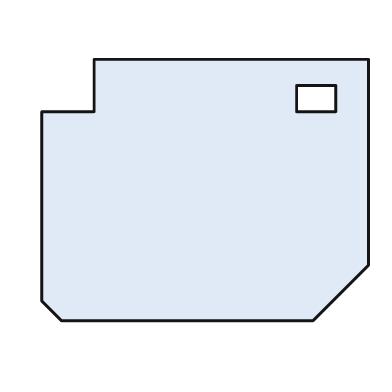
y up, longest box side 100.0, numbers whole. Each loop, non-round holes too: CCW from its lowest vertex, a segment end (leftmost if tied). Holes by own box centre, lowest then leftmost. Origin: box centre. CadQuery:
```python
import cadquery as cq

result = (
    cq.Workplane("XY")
    .moveTo(-44.0, -40.0)
    .lineTo(33.0, -40.0)
    .lineTo(50.0, -23.0)
    .lineTo(50.0, 40.0)
    .lineTo(-34.0, 40.0)
    .lineTo(-34.0, 24.0)
    .lineTo(-50.0, 24.0)
    .lineTo(-50.0, -34.0)
    .close()
    .moveTo(28.0, 24.0)
    .lineTo(40.0, 24.0)
    .lineTo(40.0, 32.0)
    .lineTo(28.0, 32.0)
    .close()
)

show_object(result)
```